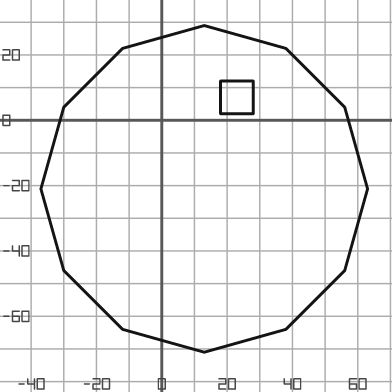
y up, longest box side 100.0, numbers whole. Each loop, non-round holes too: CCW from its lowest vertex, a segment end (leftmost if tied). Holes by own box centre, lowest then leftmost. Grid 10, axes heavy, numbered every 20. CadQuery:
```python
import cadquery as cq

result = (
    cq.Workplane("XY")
    .moveTo(13.0, -71.0)
    .lineTo(38.0, -64.0)
    .lineTo(56.0, -46.0)
    .lineTo(63.0, -21.0)
    .lineTo(56.0, 4.0)
    .lineTo(38.0, 22.0)
    .lineTo(13.0, 29.0)
    .lineTo(-12.0, 22.0)
    .lineTo(-30.0, 4.0)
    .lineTo(-37.0, -21.0)
    .lineTo(-30.0, -46.0)
    .lineTo(-12.0, -64.0)
    .close()
    .moveTo(18.0, 2.0)
    .lineTo(28.0, 2.0)
    .lineTo(28.0, 12.0)
    .lineTo(18.0, 12.0)
    .close()
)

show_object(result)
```